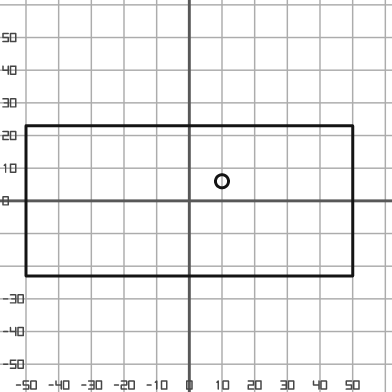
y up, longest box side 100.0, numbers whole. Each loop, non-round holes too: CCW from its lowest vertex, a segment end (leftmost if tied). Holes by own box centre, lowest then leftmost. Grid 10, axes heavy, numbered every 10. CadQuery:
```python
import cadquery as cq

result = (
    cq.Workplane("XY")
    .moveTo(-50.0, -23.0)
    .lineTo(50.0, -23.0)
    .lineTo(50.0, 23.0)
    .lineTo(-50.0, 23.0)
    .close()
    .moveTo(10.0, 6.0)
    .circle(2.0)
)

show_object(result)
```